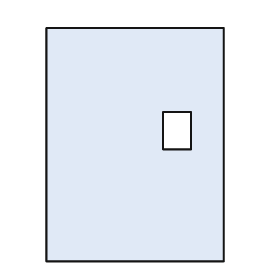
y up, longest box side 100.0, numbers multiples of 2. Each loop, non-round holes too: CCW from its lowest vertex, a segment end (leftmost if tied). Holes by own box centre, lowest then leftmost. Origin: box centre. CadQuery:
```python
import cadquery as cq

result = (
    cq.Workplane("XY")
    .moveTo(-38.0, -50.0)
    .lineTo(38.0, -50.0)
    .lineTo(38.0, 50.0)
    .lineTo(-38.0, 50.0)
    .close()
    .moveTo(12.0, -2.0)
    .lineTo(24.0, -2.0)
    .lineTo(24.0, 14.0)
    .lineTo(12.0, 14.0)
    .close()
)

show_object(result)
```